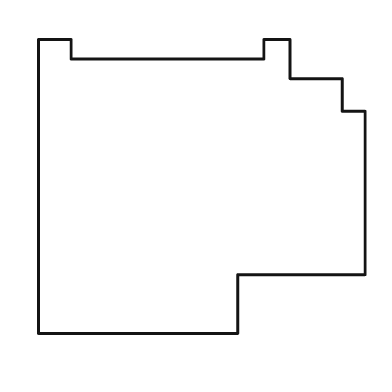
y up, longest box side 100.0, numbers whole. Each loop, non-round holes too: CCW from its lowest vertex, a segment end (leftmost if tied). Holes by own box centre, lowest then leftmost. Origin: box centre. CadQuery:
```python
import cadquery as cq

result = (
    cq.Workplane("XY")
    .moveTo(-50.0, -45.0)
    .lineTo(11.0, -45.0)
    .lineTo(11.0, -27.0)
    .lineTo(50.0, -27.0)
    .lineTo(50.0, 23.0)
    .lineTo(43.0, 23.0)
    .lineTo(43.0, 33.0)
    .lineTo(27.0, 33.0)
    .lineTo(27.0, 45.0)
    .lineTo(19.0, 45.0)
    .lineTo(19.0, 39.0)
    .lineTo(-40.0, 39.0)
    .lineTo(-40.0, 45.0)
    .lineTo(-50.0, 45.0)
    .close()
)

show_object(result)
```